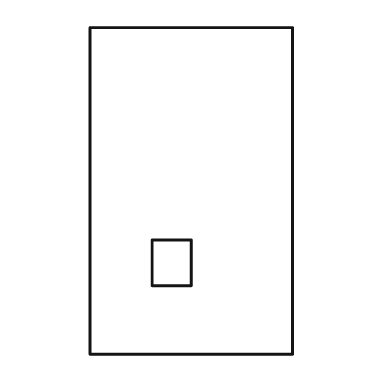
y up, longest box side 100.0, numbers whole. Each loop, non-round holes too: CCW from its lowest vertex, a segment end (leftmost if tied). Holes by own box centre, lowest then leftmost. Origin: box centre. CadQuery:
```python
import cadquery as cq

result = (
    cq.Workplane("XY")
    .moveTo(-31.0, -50.0)
    .lineTo(31.0, -50.0)
    .lineTo(31.0, 50.0)
    .lineTo(-31.0, 50.0)
    .close()
    .moveTo(-12.0, -29.0)
    .lineTo(0.0, -29.0)
    .lineTo(0.0, -15.0)
    .lineTo(-12.0, -15.0)
    .close()
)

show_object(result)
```